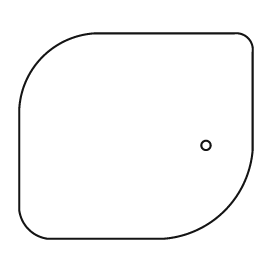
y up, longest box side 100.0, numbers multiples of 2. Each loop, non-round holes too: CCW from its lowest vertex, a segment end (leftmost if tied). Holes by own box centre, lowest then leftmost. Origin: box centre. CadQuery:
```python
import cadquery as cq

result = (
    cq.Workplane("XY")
    .moveTo(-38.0, -44.0)
    .lineTo(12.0, -44.0)
    .threePointArc((38.0, -32.0), (50.0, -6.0))
    .lineTo(50.0, 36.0)
    .threePointArc((48.0, 42.0), (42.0, 44.0))
    .lineTo(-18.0, 44.0)
    .threePointArc((-40.0, 34.0), (-50.0, 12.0))
    .lineTo(-50.0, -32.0)
    .threePointArc((-46.0, -40.0), (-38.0, -44.0))
    .close()
    .moveTo(30.0, -4.0)
    .circle(2.0)
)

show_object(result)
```